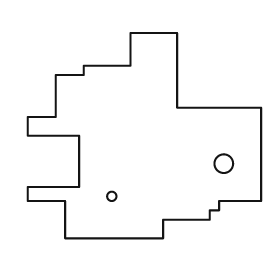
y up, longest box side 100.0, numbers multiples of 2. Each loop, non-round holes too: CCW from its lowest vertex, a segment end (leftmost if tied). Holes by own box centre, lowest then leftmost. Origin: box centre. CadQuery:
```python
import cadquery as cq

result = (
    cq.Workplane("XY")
    .moveTo(-34.0, -44.0)
    .lineTo(8.0, -44.0)
    .lineTo(8.0, -36.0)
    .lineTo(28.0, -36.0)
    .lineTo(28.0, -32.0)
    .lineTo(32.0, -32.0)
    .lineTo(32.0, -28.0)
    .lineTo(50.0, -28.0)
    .lineTo(50.0, 12.0)
    .lineTo(14.0, 12.0)
    .lineTo(14.0, 44.0)
    .lineTo(-6.0, 44.0)
    .lineTo(-6.0, 30.0)
    .lineTo(-26.0, 30.0)
    .lineTo(-26.0, 26.0)
    .lineTo(-38.0, 26.0)
    .lineTo(-38.0, 8.0)
    .lineTo(-50.0, 8.0)
    .lineTo(-50.0, 0.0)
    .lineTo(-28.0, 0.0)
    .lineTo(-28.0, -22.0)
    .lineTo(-50.0, -22.0)
    .lineTo(-50.0, -28.0)
    .lineTo(-34.0, -28.0)
    .close()
    .moveTo(-14.0, -26.0)
    .circle(2.0)
    .moveTo(34.0, -12.0)
    .circle(4.0)
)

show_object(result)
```